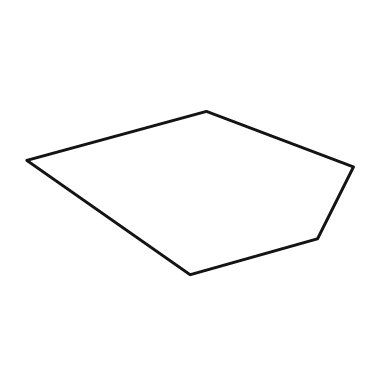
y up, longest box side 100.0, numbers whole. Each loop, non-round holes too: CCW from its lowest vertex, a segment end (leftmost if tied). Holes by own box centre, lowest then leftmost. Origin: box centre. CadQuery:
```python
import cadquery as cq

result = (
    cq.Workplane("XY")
    .moveTo(0.0, -25.0)
    .lineTo(39.0, -14.0)
    .lineTo(50.0, 8.0)
    .lineTo(5.0, 25.0)
    .lineTo(-50.0, 10.0)
    .close()
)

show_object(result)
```